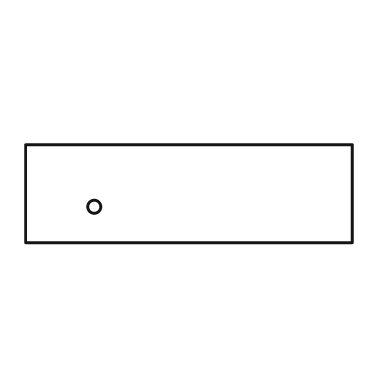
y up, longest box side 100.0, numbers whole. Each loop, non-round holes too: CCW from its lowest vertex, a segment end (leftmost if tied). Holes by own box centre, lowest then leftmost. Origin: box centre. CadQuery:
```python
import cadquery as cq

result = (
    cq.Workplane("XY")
    .moveTo(-50.0, -15.0)
    .lineTo(50.0, -15.0)
    .lineTo(50.0, 15.0)
    .lineTo(-50.0, 15.0)
    .close()
    .moveTo(-29.0, -4.0)
    .circle(2.0)
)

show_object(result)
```